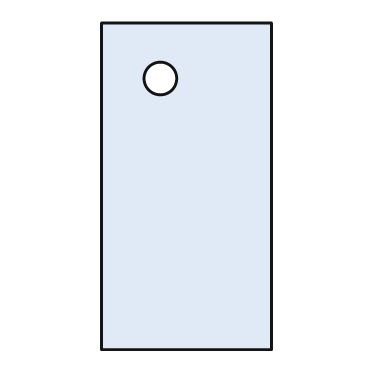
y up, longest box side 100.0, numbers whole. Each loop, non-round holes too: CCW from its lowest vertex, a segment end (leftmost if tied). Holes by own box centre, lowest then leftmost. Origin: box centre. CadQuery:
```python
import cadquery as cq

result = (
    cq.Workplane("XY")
    .moveTo(-26.0, -50.0)
    .lineTo(26.0, -50.0)
    .lineTo(26.0, 50.0)
    .lineTo(-26.0, 50.0)
    .close()
    .moveTo(-8.0, 33.0)
    .circle(5.0)
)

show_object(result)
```